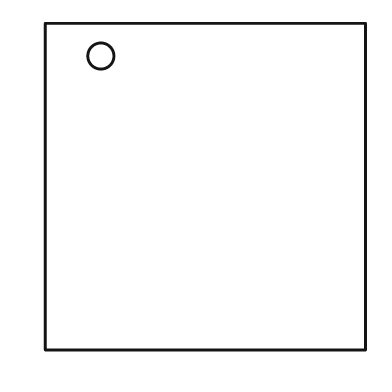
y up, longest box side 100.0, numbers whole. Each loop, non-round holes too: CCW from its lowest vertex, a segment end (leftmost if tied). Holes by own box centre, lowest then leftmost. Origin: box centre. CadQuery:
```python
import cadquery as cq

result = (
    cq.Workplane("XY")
    .moveTo(-49.0, -50.0)
    .lineTo(49.0, -50.0)
    .lineTo(49.0, 50.0)
    .lineTo(-49.0, 50.0)
    .close()
    .moveTo(-32.0, 40.0)
    .circle(4.0)
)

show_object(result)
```